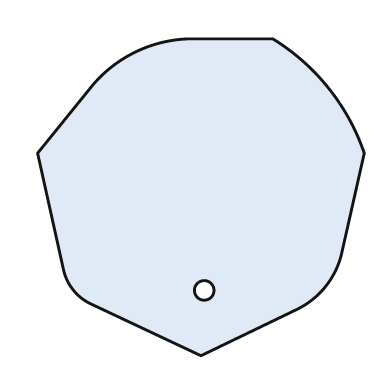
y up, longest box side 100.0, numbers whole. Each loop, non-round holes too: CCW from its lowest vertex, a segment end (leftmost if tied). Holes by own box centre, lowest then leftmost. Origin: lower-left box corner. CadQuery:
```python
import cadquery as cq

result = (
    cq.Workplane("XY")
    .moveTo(50.0, 0.0)
    .lineTo(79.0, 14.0)
    .threePointArc((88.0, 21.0), (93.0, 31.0))
    .lineTo(100.0, 62.0)
    .threePointArc((89.0, 82.0), (72.0, 97.0))
    .lineTo(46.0, 97.0)
    .threePointArc((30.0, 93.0), (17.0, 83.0))
    .lineTo(0.0, 62.0)
    .lineTo(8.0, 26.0)
    .threePointArc((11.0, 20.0), (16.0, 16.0))
    .close()
    .moveTo(51.0, 20.0)
    .circle(3.0)
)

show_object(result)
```